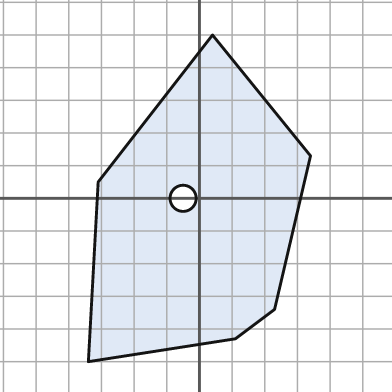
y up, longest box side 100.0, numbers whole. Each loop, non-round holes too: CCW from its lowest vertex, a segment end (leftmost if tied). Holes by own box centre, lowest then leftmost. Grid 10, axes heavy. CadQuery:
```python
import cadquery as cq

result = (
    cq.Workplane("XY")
    .moveTo(-34.0, -50.0)
    .lineTo(11.0, -43.0)
    .lineTo(23.0, -34.0)
    .lineTo(34.0, 13.0)
    .lineTo(4.0, 50.0)
    .lineTo(-31.0, 5.0)
    .close()
    .moveTo(-5.0, 0.0)
    .circle(4.0)
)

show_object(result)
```